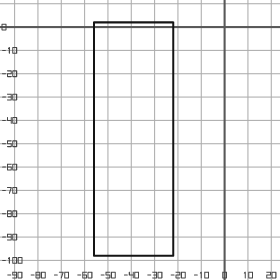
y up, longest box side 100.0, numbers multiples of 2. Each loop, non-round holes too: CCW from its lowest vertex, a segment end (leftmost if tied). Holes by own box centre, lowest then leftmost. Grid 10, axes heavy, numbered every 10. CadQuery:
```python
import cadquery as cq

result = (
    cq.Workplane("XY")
    .moveTo(-56.0, -98.0)
    .lineTo(-22.0, -98.0)
    .lineTo(-22.0, 2.0)
    .lineTo(-56.0, 2.0)
    .close()
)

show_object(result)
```